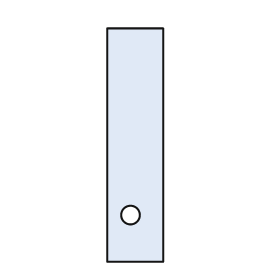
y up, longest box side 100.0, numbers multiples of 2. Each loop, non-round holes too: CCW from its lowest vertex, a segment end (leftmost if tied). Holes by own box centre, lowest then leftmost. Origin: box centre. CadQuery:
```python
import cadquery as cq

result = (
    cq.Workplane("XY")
    .moveTo(-12.0, -50.0)
    .lineTo(12.0, -50.0)
    .lineTo(12.0, 50.0)
    .lineTo(-12.0, 50.0)
    .close()
    .moveTo(-2.0, -30.0)
    .circle(4.0)
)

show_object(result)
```